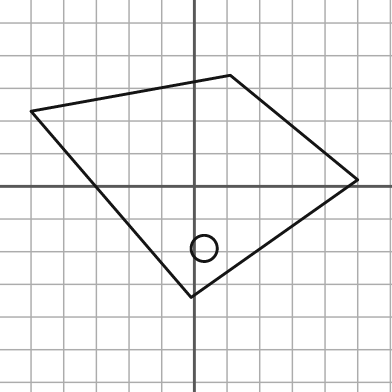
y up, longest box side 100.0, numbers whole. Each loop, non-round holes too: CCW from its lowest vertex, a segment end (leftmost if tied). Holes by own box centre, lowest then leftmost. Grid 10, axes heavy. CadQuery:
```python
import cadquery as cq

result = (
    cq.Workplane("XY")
    .moveTo(-1.0, -34.0)
    .lineTo(50.0, 2.0)
    .lineTo(11.0, 34.0)
    .lineTo(-50.0, 23.0)
    .close()
    .moveTo(3.0, -19.0)
    .circle(4.0)
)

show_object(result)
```